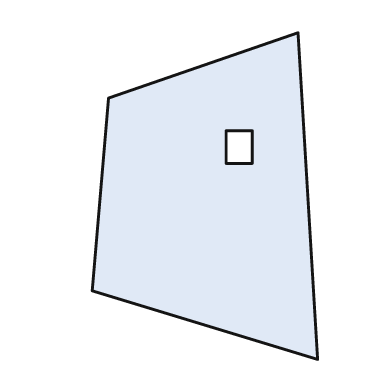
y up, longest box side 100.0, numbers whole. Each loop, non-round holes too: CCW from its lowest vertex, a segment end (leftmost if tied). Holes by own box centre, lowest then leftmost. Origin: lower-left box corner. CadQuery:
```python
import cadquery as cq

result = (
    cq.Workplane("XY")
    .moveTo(69.0, 0.0)
    .lineTo(63.0, 100.0)
    .lineTo(5.0, 80.0)
    .lineTo(0.0, 21.0)
    .close()
    .moveTo(41.0, 60.0)
    .lineTo(49.0, 60.0)
    .lineTo(49.0, 70.0)
    .lineTo(41.0, 70.0)
    .close()
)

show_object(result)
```